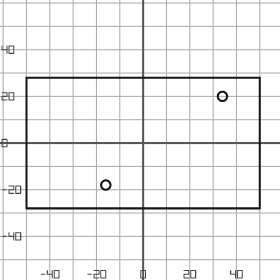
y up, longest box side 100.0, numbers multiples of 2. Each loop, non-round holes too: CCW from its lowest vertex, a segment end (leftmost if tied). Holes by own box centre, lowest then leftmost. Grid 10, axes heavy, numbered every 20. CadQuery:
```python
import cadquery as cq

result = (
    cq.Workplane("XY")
    .moveTo(-50.0, -28.0)
    .lineTo(50.0, -28.0)
    .lineTo(50.0, 28.0)
    .lineTo(-50.0, 28.0)
    .close()
    .moveTo(-16.0, -18.0)
    .circle(2.0)
    .moveTo(34.0, 20.0)
    .circle(2.0)
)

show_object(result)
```